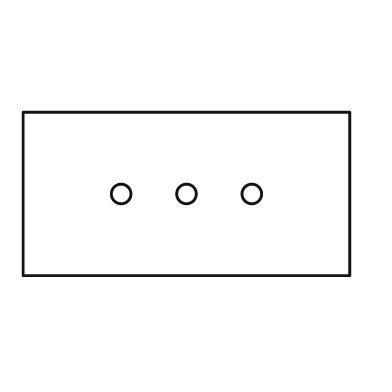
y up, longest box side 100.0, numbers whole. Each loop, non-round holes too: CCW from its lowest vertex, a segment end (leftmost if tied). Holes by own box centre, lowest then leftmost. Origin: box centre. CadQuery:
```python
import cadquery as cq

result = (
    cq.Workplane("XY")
    .moveTo(-50.0, -25.0)
    .lineTo(50.0, -25.0)
    .lineTo(50.0, 25.0)
    .lineTo(-50.0, 25.0)
    .close()
    .moveTo(-20.0, 0.0)
    .circle(3.0)
    .moveTo(0.0, 0.0)
    .circle(3.0)
    .moveTo(20.0, 0.0)
    .circle(3.0)
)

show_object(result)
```